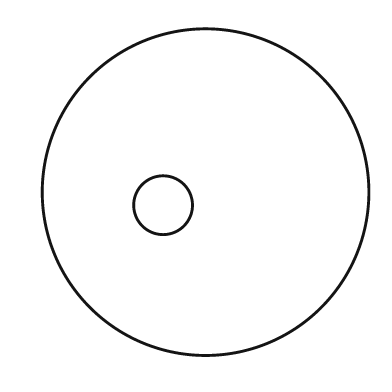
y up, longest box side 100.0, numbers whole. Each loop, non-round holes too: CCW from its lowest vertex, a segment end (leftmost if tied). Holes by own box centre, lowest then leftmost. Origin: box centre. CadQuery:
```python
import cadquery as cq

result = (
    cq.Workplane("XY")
    .moveTo(0.0, 0.0)
    .circle(50.0)
    .moveTo(-13.0, -4.0)
    .circle(9.0)
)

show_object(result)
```